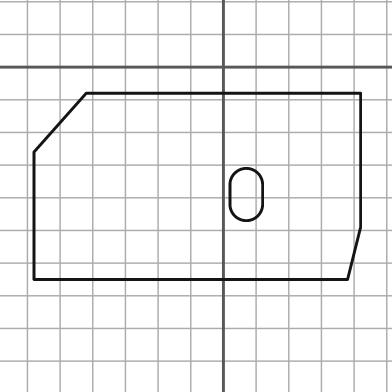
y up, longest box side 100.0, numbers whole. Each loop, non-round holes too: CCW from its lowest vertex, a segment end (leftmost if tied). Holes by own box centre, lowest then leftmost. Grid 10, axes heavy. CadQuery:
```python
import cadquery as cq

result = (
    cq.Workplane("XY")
    .moveTo(-58.0, -65.0)
    .lineTo(38.0, -65.0)
    .lineTo(42.0, -49.0)
    .lineTo(42.0, -8.0)
    .lineTo(-42.0, -8.0)
    .lineTo(-58.0, -26.0)
    .close()
    .moveTo(2.0, -42.0)
    .threePointArc((7.0, -47.0), (12.0, -42.0))
    .lineTo(12.0, -36.0)
    .threePointArc((7.0, -31.0), (2.0, -36.0))
    .close()
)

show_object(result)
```